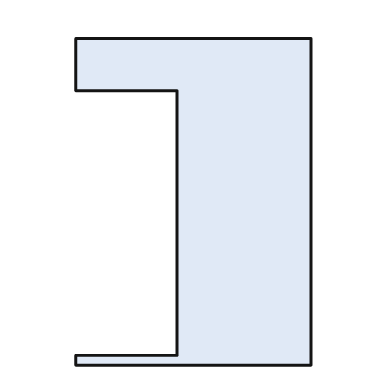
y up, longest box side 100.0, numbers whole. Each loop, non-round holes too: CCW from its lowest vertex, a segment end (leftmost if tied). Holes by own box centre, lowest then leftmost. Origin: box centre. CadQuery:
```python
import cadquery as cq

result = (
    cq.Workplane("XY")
    .moveTo(-36.0, -50.0)
    .lineTo(36.0, -50.0)
    .lineTo(36.0, 50.0)
    .lineTo(-36.0, 50.0)
    .lineTo(-36.0, 34.0)
    .lineTo(-5.0, 34.0)
    .lineTo(-5.0, -47.0)
    .lineTo(-36.0, -47.0)
    .close()
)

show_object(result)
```